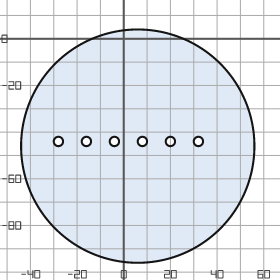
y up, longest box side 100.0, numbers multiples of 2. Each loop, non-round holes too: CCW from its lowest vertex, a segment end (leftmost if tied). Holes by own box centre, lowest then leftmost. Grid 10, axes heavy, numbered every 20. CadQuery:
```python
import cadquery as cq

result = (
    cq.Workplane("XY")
    .moveTo(6.0, -46.0)
    .circle(50.0)
    .moveTo(-28.0, -44.0)
    .circle(2.0)
    .moveTo(-16.0, -44.0)
    .circle(2.0)
    .moveTo(-4.0, -44.0)
    .circle(2.0)
    .moveTo(8.0, -44.0)
    .circle(2.0)
    .moveTo(20.0, -44.0)
    .circle(2.0)
    .moveTo(32.0, -44.0)
    .circle(2.0)
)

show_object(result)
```